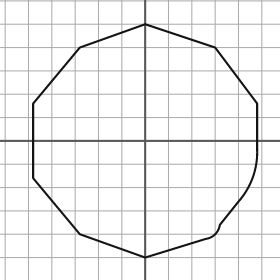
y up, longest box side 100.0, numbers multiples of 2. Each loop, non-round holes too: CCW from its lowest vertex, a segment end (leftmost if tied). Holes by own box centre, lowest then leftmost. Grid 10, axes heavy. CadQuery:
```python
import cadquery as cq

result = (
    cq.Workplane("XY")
    .moveTo(0.0, -50.0)
    .lineTo(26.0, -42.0)
    .threePointArc((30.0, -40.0), (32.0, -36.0))
    .lineTo(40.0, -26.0)
    .threePointArc((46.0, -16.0), (48.0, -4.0))
    .lineTo(48.0, 16.0)
    .lineTo(30.0, 40.0)
    .lineTo(0.0, 50.0)
    .lineTo(-28.0, 40.0)
    .lineTo(-48.0, 16.0)
    .lineTo(-48.0, -16.0)
    .lineTo(-28.0, -40.0)
    .close()
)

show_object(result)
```